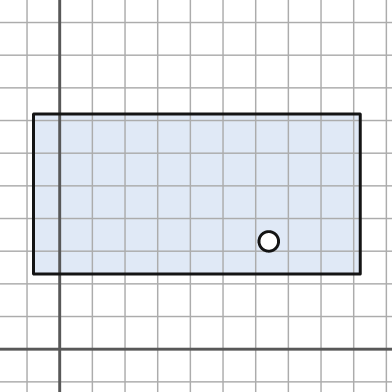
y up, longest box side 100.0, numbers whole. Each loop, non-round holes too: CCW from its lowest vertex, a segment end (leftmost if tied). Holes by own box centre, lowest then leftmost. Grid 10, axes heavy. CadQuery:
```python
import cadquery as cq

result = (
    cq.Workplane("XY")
    .moveTo(-8.0, 23.0)
    .lineTo(92.0, 23.0)
    .lineTo(92.0, 72.0)
    .lineTo(-8.0, 72.0)
    .close()
    .moveTo(64.0, 33.0)
    .circle(3.0)
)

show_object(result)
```